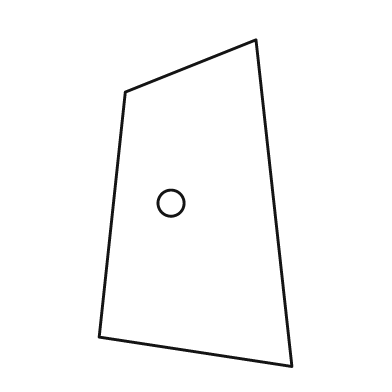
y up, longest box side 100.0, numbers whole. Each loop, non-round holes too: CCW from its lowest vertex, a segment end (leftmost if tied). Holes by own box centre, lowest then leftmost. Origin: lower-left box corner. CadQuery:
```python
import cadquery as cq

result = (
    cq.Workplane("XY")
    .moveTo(59.0, 0.0)
    .lineTo(48.0, 100.0)
    .lineTo(8.0, 84.0)
    .lineTo(0.0, 9.0)
    .close()
    .moveTo(22.0, 50.0)
    .circle(4.0)
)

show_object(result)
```